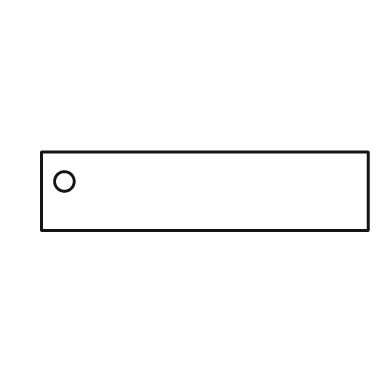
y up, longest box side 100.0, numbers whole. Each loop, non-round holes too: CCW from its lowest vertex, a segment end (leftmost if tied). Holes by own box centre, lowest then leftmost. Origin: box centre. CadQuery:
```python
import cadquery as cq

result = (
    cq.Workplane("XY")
    .moveTo(-50.0, -12.0)
    .lineTo(50.0, -12.0)
    .lineTo(50.0, 12.0)
    .lineTo(-50.0, 12.0)
    .close()
    .moveTo(-43.0, 3.0)
    .circle(3.0)
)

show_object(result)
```